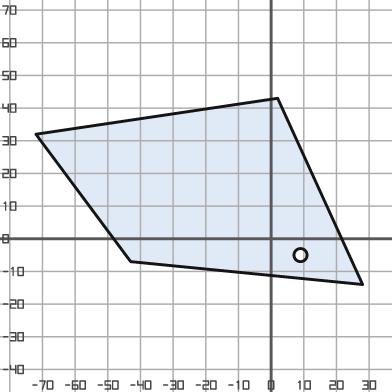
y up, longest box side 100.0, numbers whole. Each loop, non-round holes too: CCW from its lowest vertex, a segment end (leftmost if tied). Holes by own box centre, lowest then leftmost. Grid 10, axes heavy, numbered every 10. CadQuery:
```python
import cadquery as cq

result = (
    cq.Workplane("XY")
    .moveTo(28.0, -14.0)
    .lineTo(2.0, 43.0)
    .lineTo(-72.0, 32.0)
    .lineTo(-43.0, -7.0)
    .close()
    .moveTo(9.0, -5.0)
    .circle(2.0)
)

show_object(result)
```